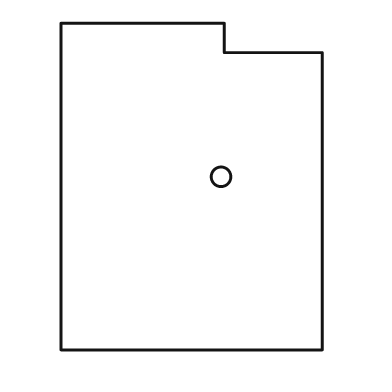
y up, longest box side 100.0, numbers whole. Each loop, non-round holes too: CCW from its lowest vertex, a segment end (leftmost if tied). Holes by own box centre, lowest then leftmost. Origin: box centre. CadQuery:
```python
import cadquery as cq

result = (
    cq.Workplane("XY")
    .moveTo(-40.0, -50.0)
    .lineTo(40.0, -50.0)
    .lineTo(40.0, 41.0)
    .lineTo(10.0, 41.0)
    .lineTo(10.0, 50.0)
    .lineTo(-40.0, 50.0)
    .close()
    .moveTo(9.0, 3.0)
    .circle(3.0)
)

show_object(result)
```